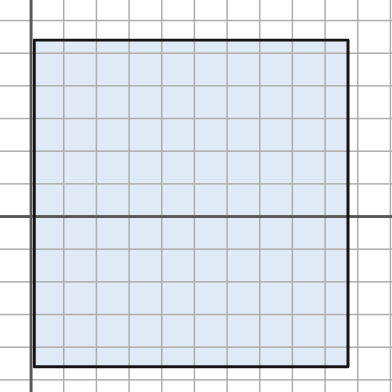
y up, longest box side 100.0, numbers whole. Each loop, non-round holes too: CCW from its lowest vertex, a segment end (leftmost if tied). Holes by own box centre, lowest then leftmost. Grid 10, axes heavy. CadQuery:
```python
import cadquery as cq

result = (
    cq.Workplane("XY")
    .moveTo(1.0, -46.0)
    .lineTo(97.0, -46.0)
    .lineTo(97.0, 54.0)
    .lineTo(1.0, 54.0)
    .close()
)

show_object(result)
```